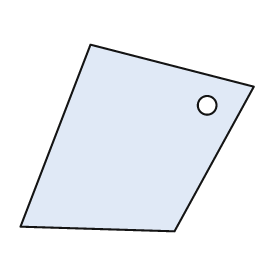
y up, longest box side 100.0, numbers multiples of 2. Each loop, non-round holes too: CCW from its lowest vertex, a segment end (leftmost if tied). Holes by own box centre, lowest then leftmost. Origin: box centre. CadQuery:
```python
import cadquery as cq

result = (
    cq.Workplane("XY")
    .moveTo(16.0, -40.0)
    .lineTo(50.0, 22.0)
    .lineTo(-20.0, 40.0)
    .lineTo(-50.0, -38.0)
    .close()
    .moveTo(30.0, 14.0)
    .circle(4.0)
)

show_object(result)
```